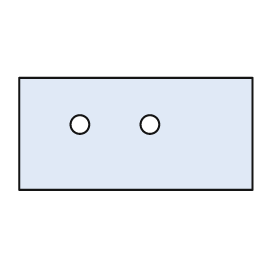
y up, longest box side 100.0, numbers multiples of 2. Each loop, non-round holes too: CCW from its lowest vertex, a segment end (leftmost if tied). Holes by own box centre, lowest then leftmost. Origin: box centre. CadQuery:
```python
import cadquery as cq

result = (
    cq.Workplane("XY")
    .moveTo(-50.0, -24.0)
    .lineTo(50.0, -24.0)
    .lineTo(50.0, 24.0)
    .lineTo(-50.0, 24.0)
    .close()
    .moveTo(-24.0, 4.0)
    .circle(4.0)
    .moveTo(6.0, 4.0)
    .circle(4.0)
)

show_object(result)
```